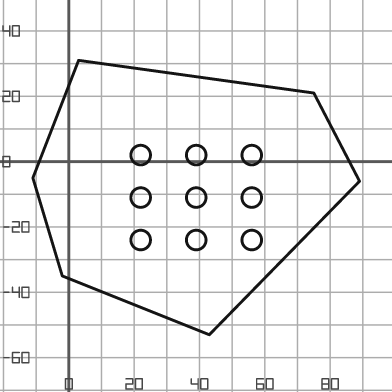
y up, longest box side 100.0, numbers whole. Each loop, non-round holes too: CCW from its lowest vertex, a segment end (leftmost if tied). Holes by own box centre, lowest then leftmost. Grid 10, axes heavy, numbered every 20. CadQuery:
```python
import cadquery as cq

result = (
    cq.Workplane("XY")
    .moveTo(43.0, -53.0)
    .lineTo(89.0, -6.0)
    .lineTo(75.0, 21.0)
    .lineTo(3.0, 31.0)
    .lineTo(-11.0, -5.0)
    .lineTo(-2.0, -35.0)
    .close()
    .moveTo(22.0, -24.0)
    .circle(3.0)
    .moveTo(39.0, -24.0)
    .circle(3.0)
    .moveTo(56.0, -24.0)
    .circle(3.0)
    .moveTo(22.0, -11.0)
    .circle(3.0)
    .moveTo(39.0, -11.0)
    .circle(3.0)
    .moveTo(56.0, -11.0)
    .circle(3.0)
    .moveTo(22.0, 2.0)
    .circle(3.0)
    .moveTo(39.0, 2.0)
    .circle(3.0)
    .moveTo(56.0, 2.0)
    .circle(3.0)
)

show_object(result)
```